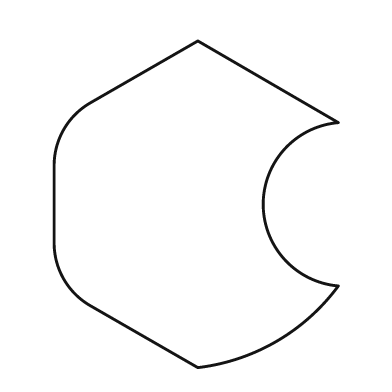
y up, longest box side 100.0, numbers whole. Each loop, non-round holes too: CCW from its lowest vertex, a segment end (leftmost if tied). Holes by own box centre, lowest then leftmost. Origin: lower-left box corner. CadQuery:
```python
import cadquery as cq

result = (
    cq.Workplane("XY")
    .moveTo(44.0, 0.0)
    .threePointArc((68.0, 8.0), (87.0, 25.0))
    .threePointArc((64.0, 50.0), (87.0, 75.0))
    .lineTo(44.0, 100.0)
    .lineTo(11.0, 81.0)
    .threePointArc((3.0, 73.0), (0.0, 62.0))
    .lineTo(0.0, 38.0)
    .threePointArc((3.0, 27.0), (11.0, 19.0))
    .close()
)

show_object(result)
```